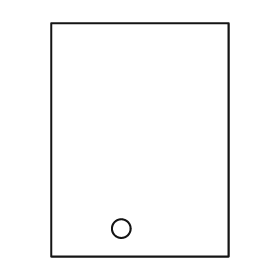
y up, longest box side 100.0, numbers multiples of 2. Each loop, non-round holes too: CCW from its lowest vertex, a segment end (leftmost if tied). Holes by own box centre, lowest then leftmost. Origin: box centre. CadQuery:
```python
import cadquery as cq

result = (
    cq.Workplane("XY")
    .moveTo(-38.0, -50.0)
    .lineTo(38.0, -50.0)
    .lineTo(38.0, 50.0)
    .lineTo(-38.0, 50.0)
    .close()
    .moveTo(-8.0, -38.0)
    .circle(4.0)
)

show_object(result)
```